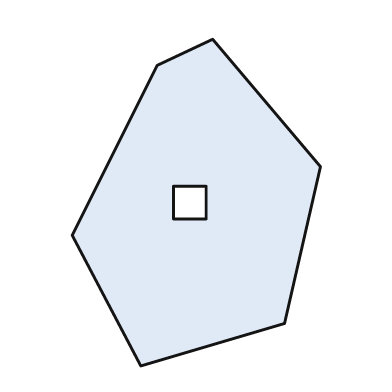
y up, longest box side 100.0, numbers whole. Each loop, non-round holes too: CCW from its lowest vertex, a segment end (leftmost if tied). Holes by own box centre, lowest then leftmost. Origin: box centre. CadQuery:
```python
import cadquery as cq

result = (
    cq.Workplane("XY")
    .moveTo(-17.0, -50.0)
    .lineTo(27.0, -37.0)
    .lineTo(38.0, 11.0)
    .lineTo(5.0, 50.0)
    .lineTo(-12.0, 42.0)
    .lineTo(-38.0, -10.0)
    .close()
    .moveTo(-7.0, -5.0)
    .lineTo(3.0, -5.0)
    .lineTo(3.0, 5.0)
    .lineTo(-7.0, 5.0)
    .close()
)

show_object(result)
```